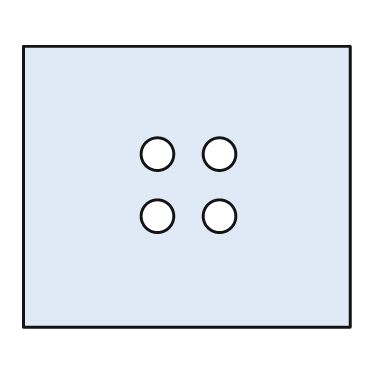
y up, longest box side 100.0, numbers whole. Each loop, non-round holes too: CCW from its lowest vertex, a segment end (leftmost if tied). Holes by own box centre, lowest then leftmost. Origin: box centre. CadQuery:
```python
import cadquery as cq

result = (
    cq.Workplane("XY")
    .moveTo(-50.0, -43.0)
    .lineTo(50.0, -43.0)
    .lineTo(50.0, 43.0)
    .lineTo(-50.0, 43.0)
    .close()
    .moveTo(-9.0, -9.0)
    .circle(5.0)
    .moveTo(10.0, -9.0)
    .circle(5.0)
    .moveTo(-9.0, 10.0)
    .circle(5.0)
    .moveTo(10.0, 10.0)
    .circle(5.0)
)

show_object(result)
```